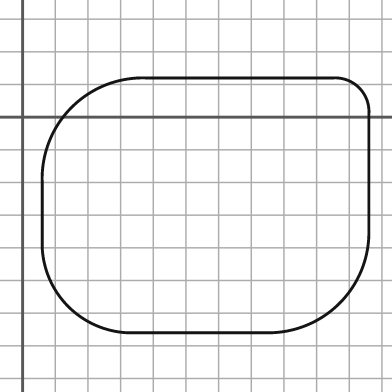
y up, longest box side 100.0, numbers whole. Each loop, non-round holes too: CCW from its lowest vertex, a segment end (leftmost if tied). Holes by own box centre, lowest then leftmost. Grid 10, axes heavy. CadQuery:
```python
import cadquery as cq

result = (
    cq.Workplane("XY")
    .moveTo(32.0, -66.0)
    .lineTo(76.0, -66.0)
    .threePointArc((97.0, -57.0), (106.0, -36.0))
    .lineTo(106.0, 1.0)
    .threePointArc((103.0, 9.0), (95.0, 12.0))
    .lineTo(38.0, 12.0)
    .threePointArc((15.0, 3.0), (6.0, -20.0))
    .lineTo(6.0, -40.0)
    .threePointArc((14.0, -58.0), (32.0, -66.0))
    .close()
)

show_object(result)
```